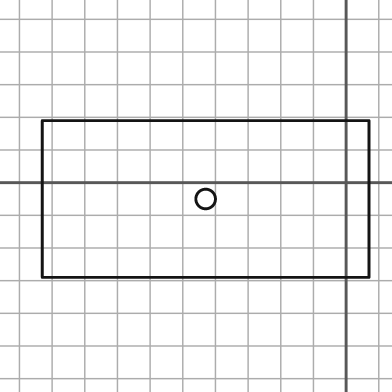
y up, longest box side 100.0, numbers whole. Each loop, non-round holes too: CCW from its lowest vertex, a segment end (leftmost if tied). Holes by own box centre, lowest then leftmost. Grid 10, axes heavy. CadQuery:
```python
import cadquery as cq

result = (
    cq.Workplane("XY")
    .moveTo(-93.0, -29.0)
    .lineTo(7.0, -29.0)
    .lineTo(7.0, 19.0)
    .lineTo(-93.0, 19.0)
    .close()
    .moveTo(-43.0, -5.0)
    .circle(3.0)
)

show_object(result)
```